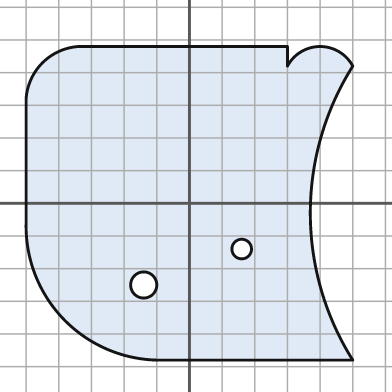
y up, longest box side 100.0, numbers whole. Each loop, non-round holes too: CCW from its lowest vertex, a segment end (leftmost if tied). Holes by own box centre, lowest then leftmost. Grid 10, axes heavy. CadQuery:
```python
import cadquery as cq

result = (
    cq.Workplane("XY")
    .moveTo(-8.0, -48.0)
    .lineTo(50.0, -48.0)
    .threePointArc((37.0, -3.0), (50.0, 42.0))
    .threePointArc((40.0, 48.0), (30.0, 42.0))
    .lineTo(30.0, 48.0)
    .lineTo(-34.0, 48.0)
    .threePointArc((-45.0, 43.0), (-50.0, 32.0))
    .lineTo(-50.0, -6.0)
    .threePointArc((-38.0, -36.0), (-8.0, -48.0))
    .close()
    .moveTo(-14.0, -25.0)
    .circle(4.0)
    .moveTo(16.0, -14.0)
    .circle(3.0)
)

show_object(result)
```